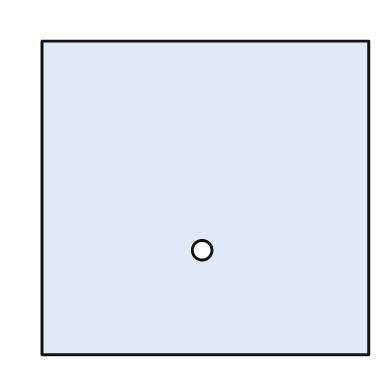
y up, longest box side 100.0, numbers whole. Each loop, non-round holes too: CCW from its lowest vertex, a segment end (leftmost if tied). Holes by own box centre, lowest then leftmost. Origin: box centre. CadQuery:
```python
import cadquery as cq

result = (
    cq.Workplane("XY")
    .moveTo(-50.0, -48.0)
    .lineTo(50.0, -48.0)
    .lineTo(50.0, 48.0)
    .lineTo(-50.0, 48.0)
    .close()
    .moveTo(-1.0, -16.0)
    .circle(3.0)
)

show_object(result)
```